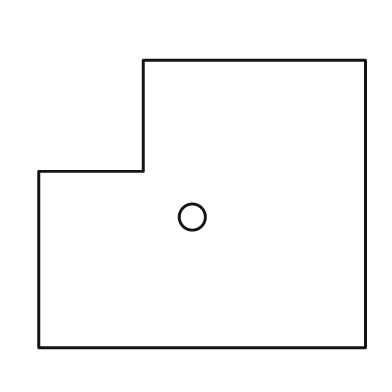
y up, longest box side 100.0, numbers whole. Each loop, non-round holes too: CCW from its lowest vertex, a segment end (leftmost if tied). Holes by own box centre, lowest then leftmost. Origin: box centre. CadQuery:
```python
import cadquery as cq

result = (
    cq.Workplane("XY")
    .moveTo(-50.0, -44.0)
    .lineTo(50.0, -44.0)
    .lineTo(50.0, 44.0)
    .lineTo(-18.0, 44.0)
    .lineTo(-18.0, 10.0)
    .lineTo(-50.0, 10.0)
    .close()
    .moveTo(-3.0, -4.0)
    .circle(4.0)
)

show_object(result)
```